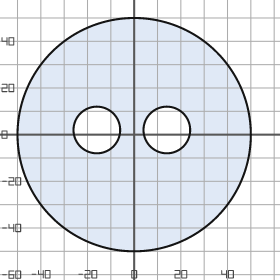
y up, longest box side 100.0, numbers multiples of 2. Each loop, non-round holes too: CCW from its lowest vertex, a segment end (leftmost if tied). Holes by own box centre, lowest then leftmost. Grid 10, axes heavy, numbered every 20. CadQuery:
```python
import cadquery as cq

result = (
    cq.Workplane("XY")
    .moveTo(0.0, 0.0)
    .circle(50.0)
    .moveTo(-16.0, 2.0)
    .circle(10.0)
    .moveTo(14.0, 2.0)
    .circle(10.0)
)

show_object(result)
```